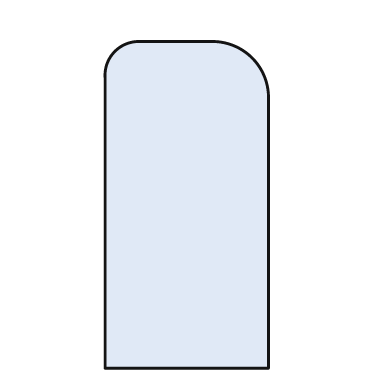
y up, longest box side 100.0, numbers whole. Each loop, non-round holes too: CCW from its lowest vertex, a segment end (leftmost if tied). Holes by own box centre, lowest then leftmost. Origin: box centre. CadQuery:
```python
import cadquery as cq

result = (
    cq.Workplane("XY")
    .moveTo(-25.0, -50.0)
    .lineTo(25.0, -50.0)
    .lineTo(25.0, 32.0)
    .threePointArc((20.0, 45.0), (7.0, 50.0))
    .lineTo(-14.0, 50.0)
    .threePointArc((-22.0, 47.0), (-25.0, 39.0))
    .close()
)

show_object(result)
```